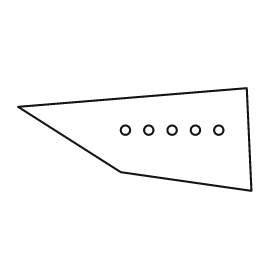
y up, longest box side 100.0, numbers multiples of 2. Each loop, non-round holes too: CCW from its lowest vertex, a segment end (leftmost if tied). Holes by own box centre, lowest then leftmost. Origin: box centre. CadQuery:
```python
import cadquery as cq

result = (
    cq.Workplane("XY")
    .moveTo(50.0, -22.0)
    .lineTo(48.0, 22.0)
    .lineTo(-50.0, 14.0)
    .lineTo(-6.0, -14.0)
    .close()
    .moveTo(-4.0, 4.0)
    .circle(2.0)
    .moveTo(6.0, 4.0)
    .circle(2.0)
    .moveTo(16.0, 4.0)
    .circle(2.0)
    .moveTo(26.0, 4.0)
    .circle(2.0)
    .moveTo(36.0, 4.0)
    .circle(2.0)
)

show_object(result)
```